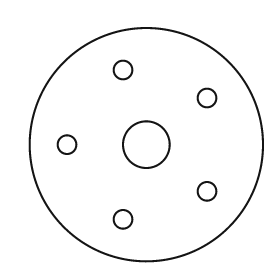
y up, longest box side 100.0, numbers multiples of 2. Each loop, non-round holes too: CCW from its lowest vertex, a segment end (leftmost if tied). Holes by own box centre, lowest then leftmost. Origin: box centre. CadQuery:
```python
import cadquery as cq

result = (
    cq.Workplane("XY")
    .moveTo(0.0, 0.0)
    .circle(50.0)
    .moveTo(-10.0, -32.0)
    .circle(4.0)
    .moveTo(26.0, -20.0)
    .circle(4.0)
    .moveTo(-34.0, 0.0)
    .circle(4.0)
    .moveTo(0.0, 0.0)
    .circle(10.0)
    .moveTo(26.0, 20.0)
    .circle(4.0)
    .moveTo(-10.0, 32.0)
    .circle(4.0)
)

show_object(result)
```